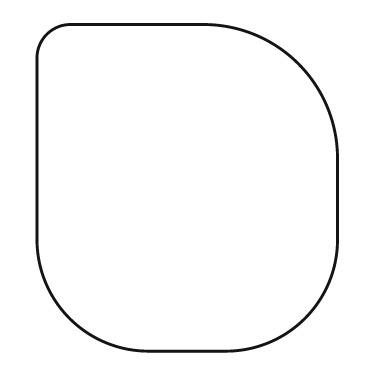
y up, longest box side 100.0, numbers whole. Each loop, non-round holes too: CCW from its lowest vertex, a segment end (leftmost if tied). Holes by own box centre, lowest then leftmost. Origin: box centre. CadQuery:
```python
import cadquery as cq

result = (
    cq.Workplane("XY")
    .moveTo(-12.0, -50.0)
    .lineTo(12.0, -50.0)
    .threePointArc((36.0, -40.0), (46.0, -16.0))
    .lineTo(46.0, 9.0)
    .threePointArc((34.0, 38.0), (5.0, 50.0))
    .lineTo(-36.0, 50.0)
    .threePointArc((-43.0, 47.0), (-46.0, 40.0))
    .lineTo(-46.0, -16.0)
    .threePointArc((-36.0, -40.0), (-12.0, -50.0))
    .close()
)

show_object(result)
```